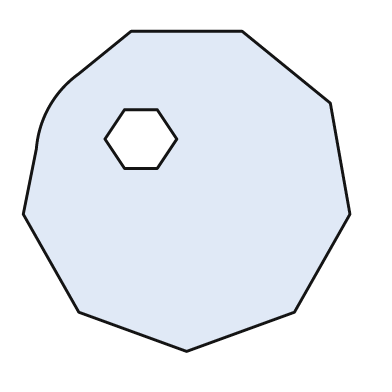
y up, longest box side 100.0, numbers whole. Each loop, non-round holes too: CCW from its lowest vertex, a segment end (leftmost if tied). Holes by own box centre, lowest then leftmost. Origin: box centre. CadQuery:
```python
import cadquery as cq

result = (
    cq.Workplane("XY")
    .moveTo(0.0, -49.0)
    .lineTo(33.0, -37.0)
    .lineTo(50.0, -7.0)
    .lineTo(44.0, 27.0)
    .lineTo(17.0, 49.0)
    .lineTo(-17.0, 49.0)
    .lineTo(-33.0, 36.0)
    .threePointArc((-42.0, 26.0), (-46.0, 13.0))
    .lineTo(-50.0, -7.0)
    .lineTo(-33.0, -37.0)
    .close()
    .moveTo(-19.0, 7.0)
    .lineTo(-9.0, 7.0)
    .lineTo(-3.0, 16.0)
    .lineTo(-9.0, 25.0)
    .lineTo(-19.0, 25.0)
    .lineTo(-25.0, 16.0)
    .close()
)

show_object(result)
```